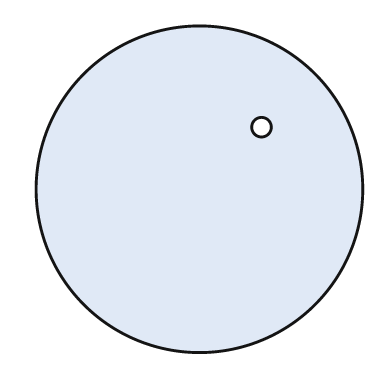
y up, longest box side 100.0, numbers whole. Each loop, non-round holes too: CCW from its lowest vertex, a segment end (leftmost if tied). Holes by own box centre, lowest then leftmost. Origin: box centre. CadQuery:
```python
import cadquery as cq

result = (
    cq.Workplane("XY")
    .moveTo(0.0, 0.0)
    .circle(50.0)
    .moveTo(19.0, 19.0)
    .circle(3.0)
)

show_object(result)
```